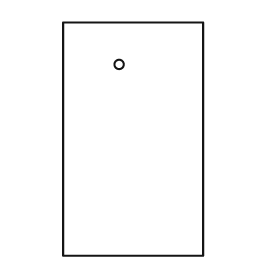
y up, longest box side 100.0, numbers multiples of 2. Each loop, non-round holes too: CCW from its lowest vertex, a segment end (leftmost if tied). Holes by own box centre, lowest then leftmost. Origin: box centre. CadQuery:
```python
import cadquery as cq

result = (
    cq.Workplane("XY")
    .moveTo(-30.0, -50.0)
    .lineTo(30.0, -50.0)
    .lineTo(30.0, 50.0)
    .lineTo(-30.0, 50.0)
    .close()
    .moveTo(-6.0, 32.0)
    .circle(2.0)
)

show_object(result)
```